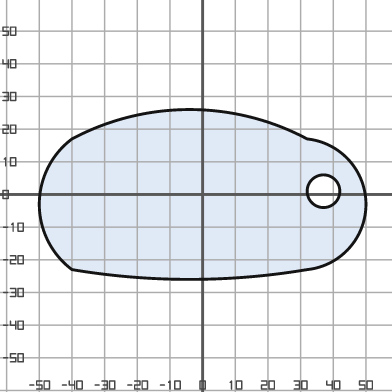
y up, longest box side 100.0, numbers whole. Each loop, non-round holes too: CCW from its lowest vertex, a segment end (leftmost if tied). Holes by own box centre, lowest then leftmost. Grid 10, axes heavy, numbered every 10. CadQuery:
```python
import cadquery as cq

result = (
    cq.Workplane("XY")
    .moveTo(-40.0, -23.0)
    .threePointArc((-4.0, -26.0), (32.0, -23.0))
    .threePointArc((50.0, -3.0), (32.0, 17.0))
    .threePointArc((-4.0, 26.0), (-40.0, 17.0))
    .threePointArc((-50.0, -3.0), (-40.0, -23.0))
    .close()
    .moveTo(37.0, 1.0)
    .circle(5.0)
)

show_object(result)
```